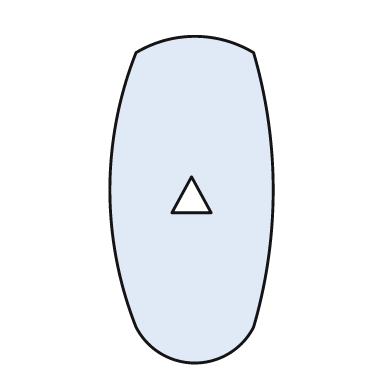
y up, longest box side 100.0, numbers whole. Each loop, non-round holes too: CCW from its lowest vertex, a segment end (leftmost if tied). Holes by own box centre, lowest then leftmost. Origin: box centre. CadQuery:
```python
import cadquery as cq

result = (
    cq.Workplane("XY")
    .moveTo(-17.0, -39.0)
    .threePointArc((1.0, -50.0), (19.0, -39.0))
    .threePointArc((25.0, 3.0), (19.0, 45.0))
    .threePointArc((1.0, 50.0), (-17.0, 45.0))
    .threePointArc((-25.0, 3.0), (-17.0, -39.0))
    .close()
    .moveTo(-6.0, -4.0)
    .lineTo(6.0, -4.0)
    .lineTo(0.0, 7.0)
    .close()
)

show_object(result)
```